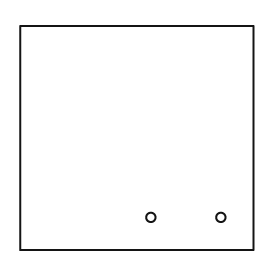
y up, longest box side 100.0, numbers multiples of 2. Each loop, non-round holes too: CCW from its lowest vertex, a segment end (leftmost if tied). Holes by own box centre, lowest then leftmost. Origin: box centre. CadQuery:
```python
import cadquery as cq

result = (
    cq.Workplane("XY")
    .moveTo(-50.0, -48.0)
    .lineTo(50.0, -48.0)
    .lineTo(50.0, 48.0)
    .lineTo(-50.0, 48.0)
    .close()
    .moveTo(6.0, -34.0)
    .circle(2.0)
    .moveTo(36.0, -34.0)
    .circle(2.0)
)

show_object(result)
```